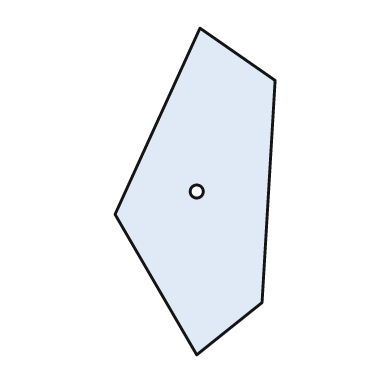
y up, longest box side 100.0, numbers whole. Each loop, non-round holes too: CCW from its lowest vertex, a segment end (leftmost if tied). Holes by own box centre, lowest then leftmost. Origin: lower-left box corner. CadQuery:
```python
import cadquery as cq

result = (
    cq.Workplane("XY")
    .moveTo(25.0, 0.0)
    .lineTo(45.0, 16.0)
    .lineTo(49.0, 84.0)
    .lineTo(26.0, 100.0)
    .lineTo(0.0, 43.0)
    .close()
    .moveTo(25.0, 50.0)
    .circle(2.0)
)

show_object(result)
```